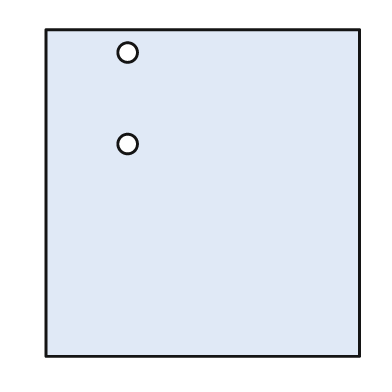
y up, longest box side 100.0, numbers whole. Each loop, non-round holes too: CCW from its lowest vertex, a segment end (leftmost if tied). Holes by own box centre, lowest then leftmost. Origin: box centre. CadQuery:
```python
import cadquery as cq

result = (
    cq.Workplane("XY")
    .moveTo(-48.0, -50.0)
    .lineTo(48.0, -50.0)
    .lineTo(48.0, 50.0)
    .lineTo(-48.0, 50.0)
    .close()
    .moveTo(-23.0, 15.0)
    .circle(3.0)
    .moveTo(-23.0, 43.0)
    .circle(3.0)
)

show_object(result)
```